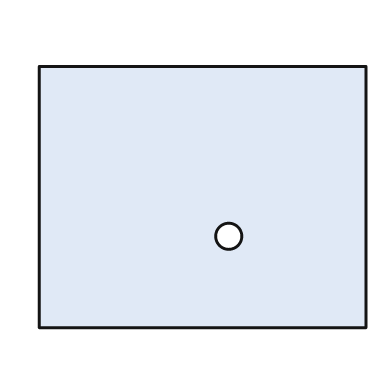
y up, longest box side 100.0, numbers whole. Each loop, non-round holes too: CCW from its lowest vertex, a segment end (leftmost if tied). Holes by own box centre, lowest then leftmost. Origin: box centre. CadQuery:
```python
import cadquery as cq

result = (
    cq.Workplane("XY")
    .moveTo(-50.0, -40.0)
    .lineTo(50.0, -40.0)
    .lineTo(50.0, 40.0)
    .lineTo(-50.0, 40.0)
    .close()
    .moveTo(8.0, -12.0)
    .circle(4.0)
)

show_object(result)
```